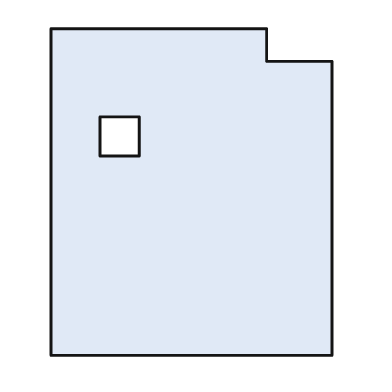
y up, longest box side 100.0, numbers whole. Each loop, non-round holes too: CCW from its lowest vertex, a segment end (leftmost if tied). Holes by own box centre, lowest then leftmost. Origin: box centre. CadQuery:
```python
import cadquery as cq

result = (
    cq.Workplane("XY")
    .moveTo(-43.0, -50.0)
    .lineTo(43.0, -50.0)
    .lineTo(43.0, 40.0)
    .lineTo(23.0, 40.0)
    .lineTo(23.0, 50.0)
    .lineTo(-43.0, 50.0)
    .close()
    .moveTo(-28.0, 11.0)
    .lineTo(-16.0, 11.0)
    .lineTo(-16.0, 23.0)
    .lineTo(-28.0, 23.0)
    .close()
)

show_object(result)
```